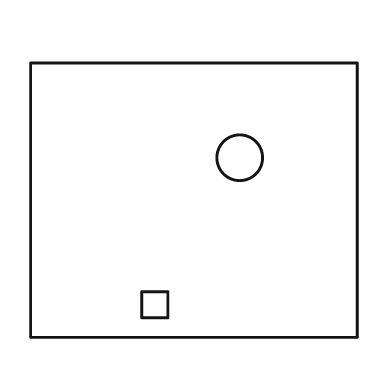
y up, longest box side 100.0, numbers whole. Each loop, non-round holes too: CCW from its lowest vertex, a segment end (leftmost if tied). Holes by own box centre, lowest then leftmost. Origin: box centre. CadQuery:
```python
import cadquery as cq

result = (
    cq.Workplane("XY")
    .moveTo(-50.0, -42.0)
    .lineTo(50.0, -42.0)
    .lineTo(50.0, 42.0)
    .lineTo(-50.0, 42.0)
    .close()
    .moveTo(-16.0, -36.0)
    .lineTo(-8.0, -36.0)
    .lineTo(-8.0, -28.0)
    .lineTo(-16.0, -28.0)
    .close()
    .moveTo(14.0, 13.0)
    .circle(7.0)
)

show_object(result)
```